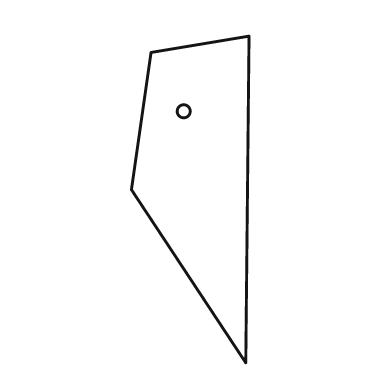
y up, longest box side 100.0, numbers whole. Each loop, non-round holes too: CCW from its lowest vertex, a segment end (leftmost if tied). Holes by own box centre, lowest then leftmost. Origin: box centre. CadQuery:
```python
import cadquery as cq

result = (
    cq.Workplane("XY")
    .moveTo(17.0, -50.0)
    .lineTo(18.0, 50.0)
    .lineTo(-12.0, 45.0)
    .lineTo(-18.0, 3.0)
    .close()
    .moveTo(-2.0, 27.0)
    .circle(2.0)
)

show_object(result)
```